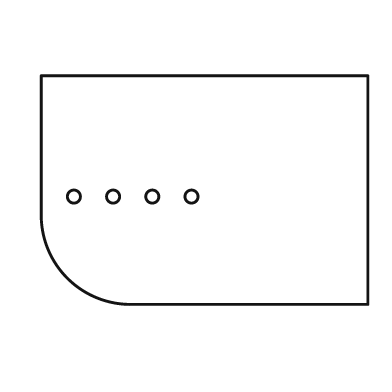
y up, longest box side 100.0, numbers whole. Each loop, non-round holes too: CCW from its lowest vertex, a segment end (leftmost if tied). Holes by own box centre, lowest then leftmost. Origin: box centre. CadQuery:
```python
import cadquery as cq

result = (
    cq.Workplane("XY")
    .moveTo(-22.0, -35.0)
    .lineTo(50.0, -35.0)
    .lineTo(50.0, 35.0)
    .lineTo(-50.0, 35.0)
    .lineTo(-50.0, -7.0)
    .threePointArc((-42.0, -27.0), (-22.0, -35.0))
    .close()
    .moveTo(-40.0, -2.0)
    .circle(2.0)
    .moveTo(-28.0, -2.0)
    .circle(2.0)
    .moveTo(-16.0, -2.0)
    .circle(2.0)
    .moveTo(-4.0, -2.0)
    .circle(2.0)
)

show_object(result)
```